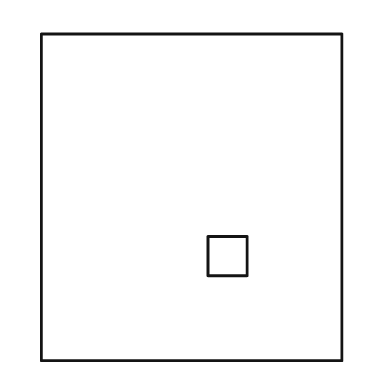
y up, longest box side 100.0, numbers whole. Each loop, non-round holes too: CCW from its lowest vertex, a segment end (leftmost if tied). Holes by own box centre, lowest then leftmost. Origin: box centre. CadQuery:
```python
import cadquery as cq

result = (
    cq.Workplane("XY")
    .moveTo(-46.0, -50.0)
    .lineTo(46.0, -50.0)
    .lineTo(46.0, 50.0)
    .lineTo(-46.0, 50.0)
    .close()
    .moveTo(5.0, -24.0)
    .lineTo(17.0, -24.0)
    .lineTo(17.0, -12.0)
    .lineTo(5.0, -12.0)
    .close()
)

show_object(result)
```